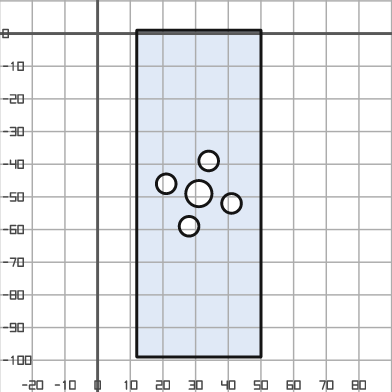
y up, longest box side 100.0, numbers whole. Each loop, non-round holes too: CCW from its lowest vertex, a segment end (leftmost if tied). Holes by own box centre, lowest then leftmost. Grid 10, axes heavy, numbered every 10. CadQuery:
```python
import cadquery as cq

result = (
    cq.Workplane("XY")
    .moveTo(12.0, -99.0)
    .lineTo(50.0, -99.0)
    .lineTo(50.0, 1.0)
    .lineTo(12.0, 1.0)
    .close()
    .moveTo(28.0, -59.0)
    .circle(3.0)
    .moveTo(41.0, -52.0)
    .circle(3.0)
    .moveTo(31.0, -49.0)
    .circle(4.0)
    .moveTo(21.0, -46.0)
    .circle(3.0)
    .moveTo(34.0, -39.0)
    .circle(3.0)
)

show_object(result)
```